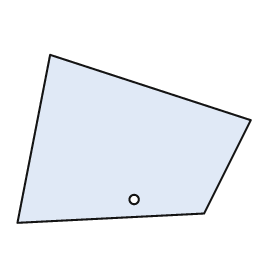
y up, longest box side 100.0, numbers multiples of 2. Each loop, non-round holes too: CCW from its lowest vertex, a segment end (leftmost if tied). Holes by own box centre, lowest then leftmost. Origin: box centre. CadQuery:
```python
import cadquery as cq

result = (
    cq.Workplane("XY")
    .moveTo(-50.0, -36.0)
    .lineTo(30.0, -32.0)
    .lineTo(50.0, 8.0)
    .lineTo(-36.0, 36.0)
    .close()
    .moveTo(0.0, -26.0)
    .circle(2.0)
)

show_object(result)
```